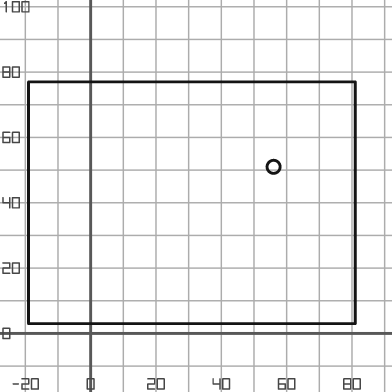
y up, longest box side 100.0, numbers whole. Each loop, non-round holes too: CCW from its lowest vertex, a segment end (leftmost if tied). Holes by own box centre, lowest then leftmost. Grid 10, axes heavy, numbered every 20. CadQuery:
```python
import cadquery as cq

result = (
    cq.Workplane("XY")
    .moveTo(-19.0, 3.0)
    .lineTo(81.0, 3.0)
    .lineTo(81.0, 77.0)
    .lineTo(-19.0, 77.0)
    .close()
    .moveTo(56.0, 51.0)
    .circle(2.0)
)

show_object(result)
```